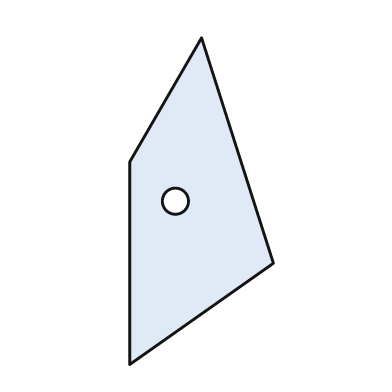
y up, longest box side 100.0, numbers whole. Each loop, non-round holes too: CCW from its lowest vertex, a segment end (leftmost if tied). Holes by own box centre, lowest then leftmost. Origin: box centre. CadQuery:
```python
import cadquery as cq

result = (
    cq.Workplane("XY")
    .moveTo(-22.0, -50.0)
    .lineTo(22.0, -19.0)
    .lineTo(0.0, 50.0)
    .lineTo(-22.0, 12.0)
    .close()
    .moveTo(-8.0, 0.0)
    .circle(4.0)
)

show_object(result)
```